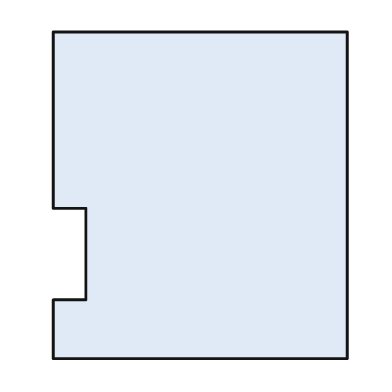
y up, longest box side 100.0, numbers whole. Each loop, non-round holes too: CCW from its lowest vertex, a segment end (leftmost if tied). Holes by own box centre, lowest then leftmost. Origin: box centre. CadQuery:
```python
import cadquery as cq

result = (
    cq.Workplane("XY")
    .moveTo(-45.0, -50.0)
    .lineTo(45.0, -50.0)
    .lineTo(45.0, 50.0)
    .lineTo(-45.0, 50.0)
    .lineTo(-45.0, -4.0)
    .lineTo(-35.0, -4.0)
    .lineTo(-35.0, -32.0)
    .lineTo(-45.0, -32.0)
    .close()
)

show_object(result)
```